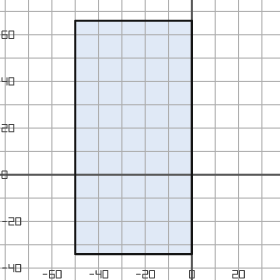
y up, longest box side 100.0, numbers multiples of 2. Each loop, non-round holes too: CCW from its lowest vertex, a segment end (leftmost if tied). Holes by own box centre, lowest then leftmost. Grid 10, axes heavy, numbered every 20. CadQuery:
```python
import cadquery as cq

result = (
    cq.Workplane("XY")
    .moveTo(-50.0, -34.0)
    .lineTo(0.0, -34.0)
    .lineTo(0.0, 66.0)
    .lineTo(-50.0, 66.0)
    .close()
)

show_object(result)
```